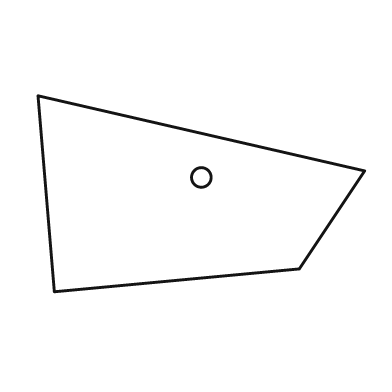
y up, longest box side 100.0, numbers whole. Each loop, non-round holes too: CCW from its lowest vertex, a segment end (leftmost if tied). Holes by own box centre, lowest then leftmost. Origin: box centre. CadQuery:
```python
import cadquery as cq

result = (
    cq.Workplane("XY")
    .moveTo(-45.0, -30.0)
    .lineTo(30.0, -23.0)
    .lineTo(50.0, 7.0)
    .lineTo(-50.0, 30.0)
    .close()
    .moveTo(0.0, 5.0)
    .circle(3.0)
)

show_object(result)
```